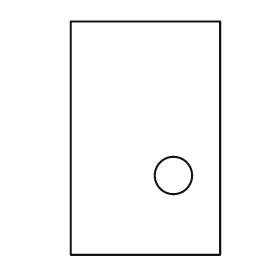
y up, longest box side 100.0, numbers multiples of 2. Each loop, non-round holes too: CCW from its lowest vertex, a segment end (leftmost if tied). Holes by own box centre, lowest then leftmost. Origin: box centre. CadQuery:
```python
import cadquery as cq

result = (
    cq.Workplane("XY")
    .moveTo(-32.0, -50.0)
    .lineTo(32.0, -50.0)
    .lineTo(32.0, 50.0)
    .lineTo(-32.0, 50.0)
    .close()
    .moveTo(12.0, -16.0)
    .circle(8.0)
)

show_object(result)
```